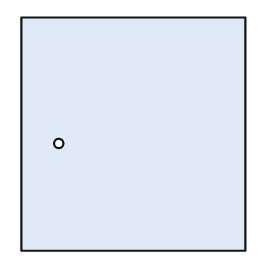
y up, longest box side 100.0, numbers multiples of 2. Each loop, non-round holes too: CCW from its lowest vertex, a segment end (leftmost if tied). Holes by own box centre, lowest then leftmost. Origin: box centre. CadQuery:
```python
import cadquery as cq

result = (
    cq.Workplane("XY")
    .moveTo(-48.0, -50.0)
    .lineTo(48.0, -50.0)
    .lineTo(48.0, 50.0)
    .lineTo(-48.0, 50.0)
    .close()
    .moveTo(-32.0, -4.0)
    .circle(2.0)
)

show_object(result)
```